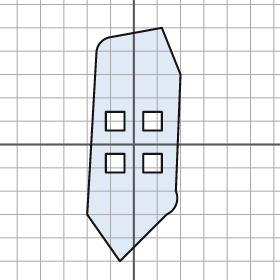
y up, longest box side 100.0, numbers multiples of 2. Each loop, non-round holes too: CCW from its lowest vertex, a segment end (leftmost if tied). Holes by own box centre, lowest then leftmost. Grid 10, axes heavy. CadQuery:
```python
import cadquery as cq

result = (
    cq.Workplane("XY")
    .moveTo(-6.0, -50.0)
    .lineTo(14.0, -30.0)
    .threePointArc((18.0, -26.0), (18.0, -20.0))
    .lineTo(20.0, 30.0)
    .lineTo(12.0, 50.0)
    .lineTo(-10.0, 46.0)
    .threePointArc((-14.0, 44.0), (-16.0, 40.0))
    .lineTo(-20.0, -30.0)
    .close()
    .moveTo(-12.0, -12.0)
    .lineTo(-4.0, -12.0)
    .lineTo(-4.0, -4.0)
    .lineTo(-12.0, -4.0)
    .close()
    .moveTo(4.0, -12.0)
    .lineTo(12.0, -12.0)
    .lineTo(12.0, -4.0)
    .lineTo(4.0, -4.0)
    .close()
    .moveTo(-12.0, 6.0)
    .lineTo(-4.0, 6.0)
    .lineTo(-4.0, 14.0)
    .lineTo(-12.0, 14.0)
    .close()
    .moveTo(4.0, 6.0)
    .lineTo(12.0, 6.0)
    .lineTo(12.0, 14.0)
    .lineTo(4.0, 14.0)
    .close()
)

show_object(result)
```